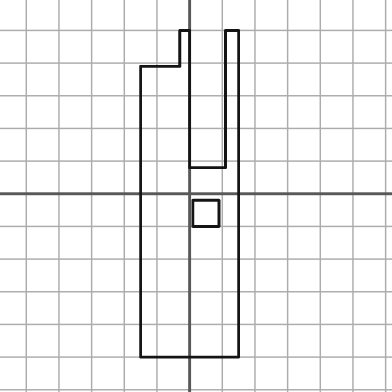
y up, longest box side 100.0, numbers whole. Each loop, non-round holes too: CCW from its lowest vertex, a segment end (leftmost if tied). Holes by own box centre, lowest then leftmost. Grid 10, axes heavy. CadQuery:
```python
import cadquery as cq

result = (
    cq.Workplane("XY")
    .moveTo(-15.0, -50.0)
    .lineTo(15.0, -50.0)
    .lineTo(15.0, 50.0)
    .lineTo(11.0, 50.0)
    .lineTo(11.0, 8.0)
    .lineTo(0.0, 8.0)
    .lineTo(0.0, 50.0)
    .lineTo(-3.0, 50.0)
    .lineTo(-3.0, 39.0)
    .lineTo(-15.0, 39.0)
    .close()
    .moveTo(1.0, -10.0)
    .lineTo(9.0, -10.0)
    .lineTo(9.0, -2.0)
    .lineTo(1.0, -2.0)
    .close()
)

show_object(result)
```